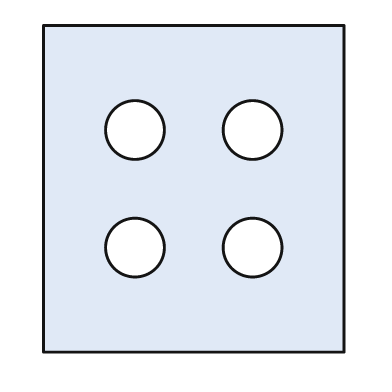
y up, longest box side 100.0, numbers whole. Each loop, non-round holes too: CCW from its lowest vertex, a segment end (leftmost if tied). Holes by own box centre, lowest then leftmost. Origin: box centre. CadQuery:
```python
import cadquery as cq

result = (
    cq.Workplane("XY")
    .moveTo(-46.0, -50.0)
    .lineTo(46.0, -50.0)
    .lineTo(46.0, 50.0)
    .lineTo(-46.0, 50.0)
    .close()
    .moveTo(-18.0, -18.0)
    .circle(9.0)
    .moveTo(18.0, -18.0)
    .circle(9.0)
    .moveTo(-18.0, 18.0)
    .circle(9.0)
    .moveTo(18.0, 18.0)
    .circle(9.0)
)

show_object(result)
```